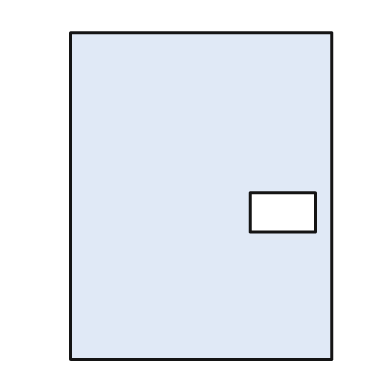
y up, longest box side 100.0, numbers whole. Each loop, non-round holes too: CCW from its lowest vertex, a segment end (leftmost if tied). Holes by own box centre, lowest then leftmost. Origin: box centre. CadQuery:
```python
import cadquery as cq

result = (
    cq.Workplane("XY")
    .moveTo(-40.0, -50.0)
    .lineTo(40.0, -50.0)
    .lineTo(40.0, 50.0)
    .lineTo(-40.0, 50.0)
    .close()
    .moveTo(15.0, -11.0)
    .lineTo(35.0, -11.0)
    .lineTo(35.0, 1.0)
    .lineTo(15.0, 1.0)
    .close()
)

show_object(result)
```